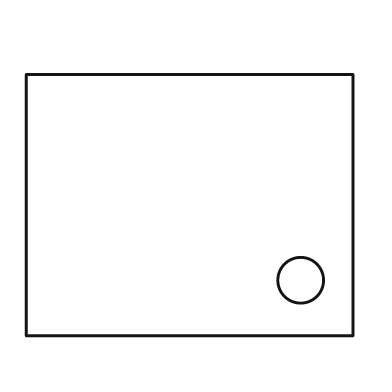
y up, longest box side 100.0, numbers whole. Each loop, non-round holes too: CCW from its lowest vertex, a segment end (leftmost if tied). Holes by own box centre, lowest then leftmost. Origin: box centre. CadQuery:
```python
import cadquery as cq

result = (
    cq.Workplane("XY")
    .moveTo(-50.0, -40.0)
    .lineTo(50.0, -40.0)
    .lineTo(50.0, 40.0)
    .lineTo(-50.0, 40.0)
    .close()
    .moveTo(34.0, -23.0)
    .circle(7.0)
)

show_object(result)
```